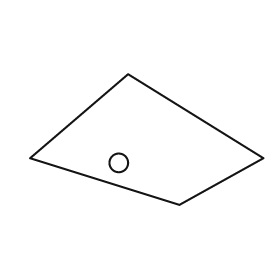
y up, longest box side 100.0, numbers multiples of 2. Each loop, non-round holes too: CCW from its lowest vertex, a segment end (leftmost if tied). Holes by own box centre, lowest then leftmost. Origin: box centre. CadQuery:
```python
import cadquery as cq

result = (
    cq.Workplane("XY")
    .moveTo(14.0, -28.0)
    .lineTo(50.0, -8.0)
    .lineTo(-8.0, 28.0)
    .lineTo(-50.0, -8.0)
    .close()
    .moveTo(-12.0, -10.0)
    .circle(4.0)
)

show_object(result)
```